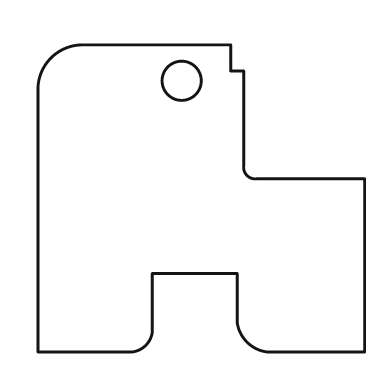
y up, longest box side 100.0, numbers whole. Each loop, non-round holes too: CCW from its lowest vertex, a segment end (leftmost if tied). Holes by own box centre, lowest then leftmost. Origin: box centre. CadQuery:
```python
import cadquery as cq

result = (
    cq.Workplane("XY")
    .moveTo(-50.0, -47.0)
    .lineTo(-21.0, -47.0)
    .threePointArc((-17.0, -45.0), (-15.0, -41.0))
    .lineTo(-15.0, -23.0)
    .lineTo(11.0, -23.0)
    .lineTo(11.0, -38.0)
    .threePointArc((14.0, -44.0), (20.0, -47.0))
    .lineTo(50.0, -47.0)
    .lineTo(50.0, 6.0)
    .lineTo(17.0, 6.0)
    .threePointArc((14.0, 7.0), (13.0, 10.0))
    .lineTo(13.0, 39.0)
    .lineTo(9.0, 39.0)
    .lineTo(9.0, 47.0)
    .lineTo(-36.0, 47.0)
    .threePointArc((-46.0, 43.0), (-50.0, 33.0))
    .close()
    .moveTo(-6.0, 36.0)
    .circle(6.0)
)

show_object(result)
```